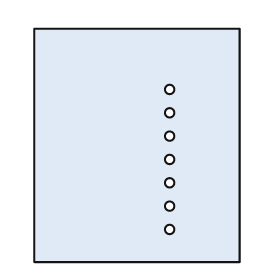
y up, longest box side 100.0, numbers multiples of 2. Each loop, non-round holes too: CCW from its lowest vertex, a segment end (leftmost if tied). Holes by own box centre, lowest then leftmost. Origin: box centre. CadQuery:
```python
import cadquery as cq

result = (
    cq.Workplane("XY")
    .moveTo(-44.0, -50.0)
    .lineTo(44.0, -50.0)
    .lineTo(44.0, 50.0)
    .lineTo(-44.0, 50.0)
    .close()
    .moveTo(14.0, -36.0)
    .circle(2.0)
    .moveTo(14.0, -26.0)
    .circle(2.0)
    .moveTo(14.0, -16.0)
    .circle(2.0)
    .moveTo(14.0, -6.0)
    .circle(2.0)
    .moveTo(14.0, 4.0)
    .circle(2.0)
    .moveTo(14.0, 14.0)
    .circle(2.0)
    .moveTo(14.0, 24.0)
    .circle(2.0)
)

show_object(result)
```